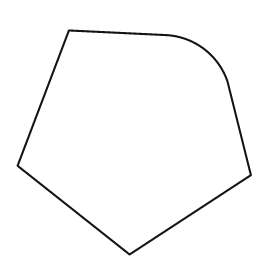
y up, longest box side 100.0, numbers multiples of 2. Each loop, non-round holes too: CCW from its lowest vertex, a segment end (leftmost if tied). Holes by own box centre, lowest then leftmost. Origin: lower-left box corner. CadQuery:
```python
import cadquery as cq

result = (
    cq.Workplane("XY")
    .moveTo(48.0, 0.0)
    .lineTo(100.0, 34.0)
    .lineTo(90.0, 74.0)
    .threePointArc((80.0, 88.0), (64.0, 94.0))
    .lineTo(22.0, 96.0)
    .lineTo(0.0, 38.0)
    .close()
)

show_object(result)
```